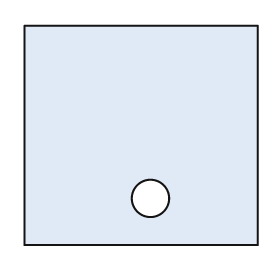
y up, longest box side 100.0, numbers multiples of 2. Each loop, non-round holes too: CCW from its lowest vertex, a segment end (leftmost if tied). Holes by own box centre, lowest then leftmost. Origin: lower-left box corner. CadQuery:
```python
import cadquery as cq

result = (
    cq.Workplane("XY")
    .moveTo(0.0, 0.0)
    .lineTo(100.0, 0.0)
    .lineTo(100.0, 94.0)
    .lineTo(0.0, 94.0)
    .close()
    .moveTo(54.0, 20.0)
    .circle(8.0)
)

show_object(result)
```